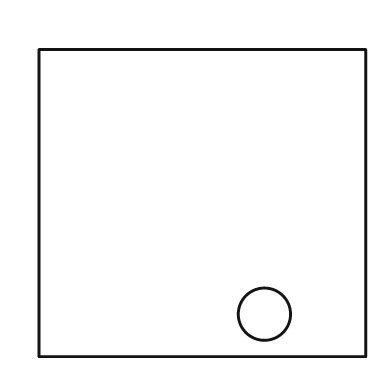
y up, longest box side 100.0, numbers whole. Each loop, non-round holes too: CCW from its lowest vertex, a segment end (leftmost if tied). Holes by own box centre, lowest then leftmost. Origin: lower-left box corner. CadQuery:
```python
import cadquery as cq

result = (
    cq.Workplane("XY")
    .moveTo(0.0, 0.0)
    .lineTo(100.0, 0.0)
    .lineTo(100.0, 94.0)
    .lineTo(0.0, 94.0)
    .close()
    .moveTo(69.0, 13.0)
    .circle(8.0)
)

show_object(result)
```